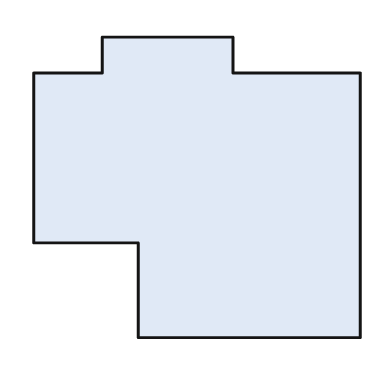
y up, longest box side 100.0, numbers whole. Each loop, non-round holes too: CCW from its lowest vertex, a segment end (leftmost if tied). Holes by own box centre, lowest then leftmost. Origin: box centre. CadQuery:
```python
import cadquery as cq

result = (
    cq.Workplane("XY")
    .moveTo(-18.0, -46.0)
    .lineTo(50.0, -46.0)
    .lineTo(50.0, 35.0)
    .lineTo(11.0, 35.0)
    .lineTo(11.0, 46.0)
    .lineTo(-29.0, 46.0)
    .lineTo(-29.0, 35.0)
    .lineTo(-50.0, 35.0)
    .lineTo(-50.0, -17.0)
    .lineTo(-18.0, -17.0)
    .close()
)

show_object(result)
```